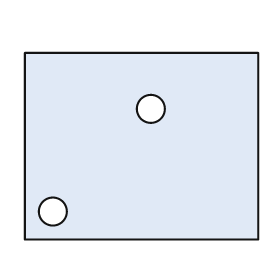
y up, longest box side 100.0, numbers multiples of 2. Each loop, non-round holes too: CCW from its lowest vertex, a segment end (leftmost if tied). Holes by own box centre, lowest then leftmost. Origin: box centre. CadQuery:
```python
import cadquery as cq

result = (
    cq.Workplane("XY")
    .moveTo(-50.0, -40.0)
    .lineTo(50.0, -40.0)
    .lineTo(50.0, 40.0)
    .lineTo(-50.0, 40.0)
    .close()
    .moveTo(-38.0, -28.0)
    .circle(6.0)
    .moveTo(4.0, 16.0)
    .circle(6.0)
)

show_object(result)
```